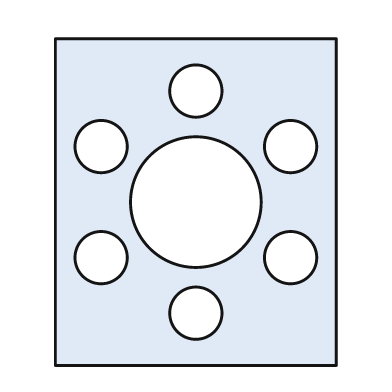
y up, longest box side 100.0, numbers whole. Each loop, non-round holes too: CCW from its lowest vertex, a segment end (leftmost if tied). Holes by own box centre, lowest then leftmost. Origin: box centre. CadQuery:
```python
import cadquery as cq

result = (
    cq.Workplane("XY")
    .moveTo(-43.0, -50.0)
    .lineTo(43.0, -50.0)
    .lineTo(43.0, 50.0)
    .lineTo(-43.0, 50.0)
    .close()
    .moveTo(0.0, -34.0)
    .circle(8.0)
    .moveTo(-29.0, -17.0)
    .circle(8.0)
    .moveTo(29.0, -17.0)
    .circle(8.0)
    .moveTo(0.0, 0.0)
    .circle(20.0)
    .moveTo(-29.0, 17.0)
    .circle(8.0)
    .moveTo(29.0, 17.0)
    .circle(8.0)
    .moveTo(0.0, 34.0)
    .circle(8.0)
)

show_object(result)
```